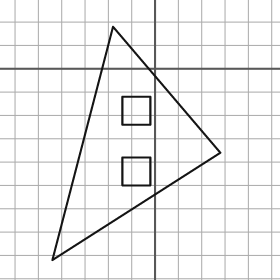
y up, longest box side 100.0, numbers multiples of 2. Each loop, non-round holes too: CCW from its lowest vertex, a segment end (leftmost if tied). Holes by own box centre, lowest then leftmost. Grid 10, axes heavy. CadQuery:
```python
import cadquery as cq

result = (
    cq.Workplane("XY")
    .moveTo(-44.0, -82.0)
    .lineTo(28.0, -36.0)
    .lineTo(-18.0, 18.0)
    .close()
    .moveTo(-14.0, -50.0)
    .lineTo(-2.0, -50.0)
    .lineTo(-2.0, -38.0)
    .lineTo(-14.0, -38.0)
    .close()
    .moveTo(-14.0, -24.0)
    .lineTo(-2.0, -24.0)
    .lineTo(-2.0, -12.0)
    .lineTo(-14.0, -12.0)
    .close()
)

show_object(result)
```